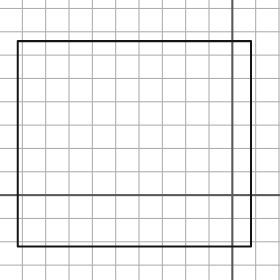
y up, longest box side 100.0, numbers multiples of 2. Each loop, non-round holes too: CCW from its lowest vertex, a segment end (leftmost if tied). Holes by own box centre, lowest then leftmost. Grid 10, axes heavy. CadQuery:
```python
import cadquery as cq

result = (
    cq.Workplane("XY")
    .moveTo(-92.0, -22.0)
    .lineTo(8.0, -22.0)
    .lineTo(8.0, 66.0)
    .lineTo(-92.0, 66.0)
    .close()
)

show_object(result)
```